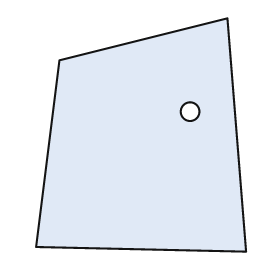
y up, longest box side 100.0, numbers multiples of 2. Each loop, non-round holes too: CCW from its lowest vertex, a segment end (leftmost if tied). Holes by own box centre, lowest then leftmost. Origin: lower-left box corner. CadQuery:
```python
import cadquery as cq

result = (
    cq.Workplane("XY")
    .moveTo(90.0, 0.0)
    .lineTo(82.0, 100.0)
    .lineTo(10.0, 82.0)
    .lineTo(0.0, 2.0)
    .close()
    .moveTo(66.0, 60.0)
    .circle(4.0)
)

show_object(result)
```